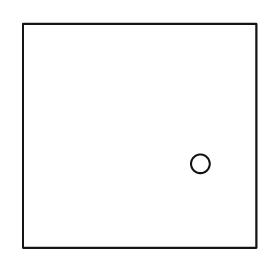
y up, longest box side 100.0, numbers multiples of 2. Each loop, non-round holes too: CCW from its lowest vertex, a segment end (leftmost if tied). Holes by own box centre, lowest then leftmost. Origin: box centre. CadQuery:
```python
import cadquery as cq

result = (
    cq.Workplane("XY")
    .moveTo(-50.0, -48.0)
    .lineTo(50.0, -48.0)
    .lineTo(50.0, 48.0)
    .lineTo(-50.0, 48.0)
    .close()
    .moveTo(26.0, -12.0)
    .circle(4.0)
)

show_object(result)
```